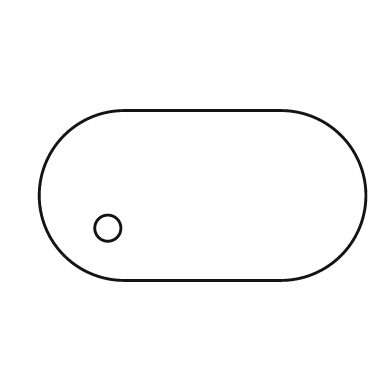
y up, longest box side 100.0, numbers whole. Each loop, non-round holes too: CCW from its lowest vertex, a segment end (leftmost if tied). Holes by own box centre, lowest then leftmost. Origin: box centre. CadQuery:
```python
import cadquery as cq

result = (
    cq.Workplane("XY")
    .moveTo(-24.0, -26.0)
    .lineTo(24.0, -26.0)
    .threePointArc((50.0, 0.0), (24.0, 26.0))
    .lineTo(-24.0, 26.0)
    .threePointArc((-50.0, 0.0), (-24.0, -26.0))
    .close()
    .moveTo(-29.0, -10.0)
    .circle(4.0)
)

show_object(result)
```